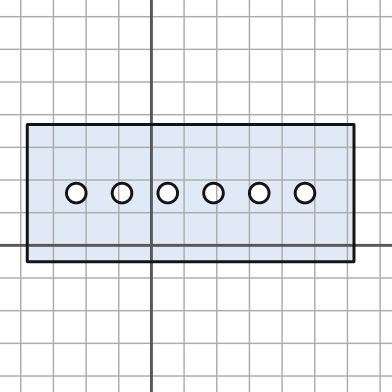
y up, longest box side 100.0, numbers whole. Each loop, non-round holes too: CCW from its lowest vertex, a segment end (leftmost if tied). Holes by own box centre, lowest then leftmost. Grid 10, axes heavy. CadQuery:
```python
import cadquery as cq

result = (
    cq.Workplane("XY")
    .moveTo(-38.0, -5.0)
    .lineTo(62.0, -5.0)
    .lineTo(62.0, 37.0)
    .lineTo(-38.0, 37.0)
    .close()
    .moveTo(-23.0, 16.0)
    .circle(3.0)
    .moveTo(-9.0, 16.0)
    .circle(3.0)
    .moveTo(5.0, 16.0)
    .circle(3.0)
    .moveTo(19.0, 16.0)
    .circle(3.0)
    .moveTo(33.0, 16.0)
    .circle(3.0)
    .moveTo(47.0, 16.0)
    .circle(3.0)
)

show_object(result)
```